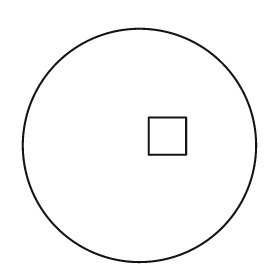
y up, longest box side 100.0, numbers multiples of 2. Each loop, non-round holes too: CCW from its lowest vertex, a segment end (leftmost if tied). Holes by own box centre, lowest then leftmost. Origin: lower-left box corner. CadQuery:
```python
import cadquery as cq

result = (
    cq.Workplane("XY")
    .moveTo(50.0, 50.0)
    .circle(50.0)
    .moveTo(54.0, 46.0)
    .lineTo(70.0, 46.0)
    .lineTo(70.0, 62.0)
    .lineTo(54.0, 62.0)
    .close()
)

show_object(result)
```